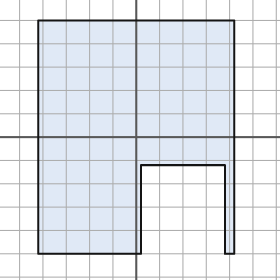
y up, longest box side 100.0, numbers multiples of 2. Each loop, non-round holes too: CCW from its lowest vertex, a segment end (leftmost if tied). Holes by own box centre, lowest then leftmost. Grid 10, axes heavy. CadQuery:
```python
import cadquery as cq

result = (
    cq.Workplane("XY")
    .moveTo(-42.0, -50.0)
    .lineTo(2.0, -50.0)
    .lineTo(2.0, -12.0)
    .lineTo(38.0, -12.0)
    .lineTo(38.0, -50.0)
    .lineTo(42.0, -50.0)
    .lineTo(42.0, 50.0)
    .lineTo(-42.0, 50.0)
    .close()
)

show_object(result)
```